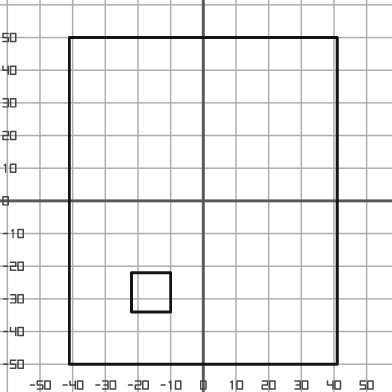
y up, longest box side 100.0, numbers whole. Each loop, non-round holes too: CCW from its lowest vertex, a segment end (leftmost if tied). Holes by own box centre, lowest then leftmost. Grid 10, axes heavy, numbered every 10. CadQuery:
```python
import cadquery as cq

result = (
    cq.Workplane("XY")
    .moveTo(-41.0, -50.0)
    .lineTo(41.0, -50.0)
    .lineTo(41.0, 50.0)
    .lineTo(-41.0, 50.0)
    .close()
    .moveTo(-22.0, -34.0)
    .lineTo(-10.0, -34.0)
    .lineTo(-10.0, -22.0)
    .lineTo(-22.0, -22.0)
    .close()
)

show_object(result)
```